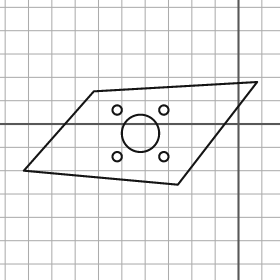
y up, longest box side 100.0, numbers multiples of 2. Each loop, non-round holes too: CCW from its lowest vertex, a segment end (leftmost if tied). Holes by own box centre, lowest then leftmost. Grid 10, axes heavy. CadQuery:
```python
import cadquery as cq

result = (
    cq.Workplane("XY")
    .moveTo(-26.0, -26.0)
    .lineTo(8.0, 18.0)
    .lineTo(-62.0, 14.0)
    .lineTo(-92.0, -20.0)
    .close()
    .moveTo(-52.0, -14.0)
    .circle(2.0)
    .moveTo(-32.0, -14.0)
    .circle(2.0)
    .moveTo(-42.0, -4.0)
    .circle(8.0)
    .moveTo(-52.0, 6.0)
    .circle(2.0)
    .moveTo(-32.0, 6.0)
    .circle(2.0)
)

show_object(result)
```